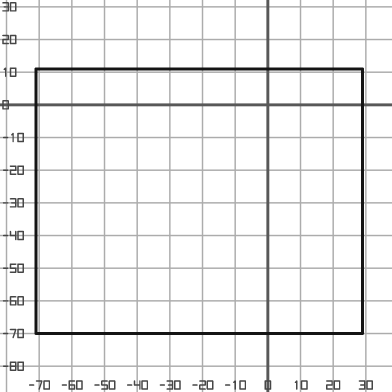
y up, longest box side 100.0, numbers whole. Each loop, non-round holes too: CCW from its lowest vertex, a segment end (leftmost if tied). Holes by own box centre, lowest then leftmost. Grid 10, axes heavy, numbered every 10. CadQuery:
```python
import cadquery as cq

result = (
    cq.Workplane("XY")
    .moveTo(-71.0, -70.0)
    .lineTo(29.0, -70.0)
    .lineTo(29.0, 11.0)
    .lineTo(-71.0, 11.0)
    .close()
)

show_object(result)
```